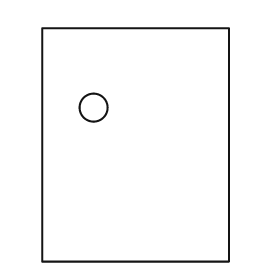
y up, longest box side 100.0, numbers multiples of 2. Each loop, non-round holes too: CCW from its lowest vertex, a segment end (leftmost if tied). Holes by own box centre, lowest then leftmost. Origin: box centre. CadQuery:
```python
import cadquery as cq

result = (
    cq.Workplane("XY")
    .moveTo(-40.0, -50.0)
    .lineTo(40.0, -50.0)
    .lineTo(40.0, 50.0)
    .lineTo(-40.0, 50.0)
    .close()
    .moveTo(-18.0, 16.0)
    .circle(6.0)
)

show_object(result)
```